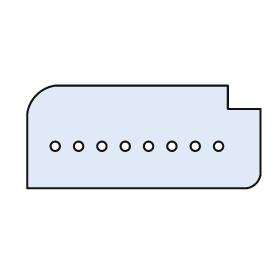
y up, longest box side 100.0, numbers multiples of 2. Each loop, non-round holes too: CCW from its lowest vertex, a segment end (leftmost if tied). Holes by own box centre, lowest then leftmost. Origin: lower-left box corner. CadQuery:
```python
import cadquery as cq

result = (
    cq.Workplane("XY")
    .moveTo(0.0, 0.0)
    .lineTo(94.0, 0.0)
    .threePointArc((98.0, 2.0), (100.0, 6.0))
    .lineTo(100.0, 34.0)
    .lineTo(86.0, 34.0)
    .lineTo(86.0, 44.0)
    .lineTo(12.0, 44.0)
    .threePointArc((4.0, 40.0), (0.0, 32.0))
    .close()
    .moveTo(12.0, 18.0)
    .circle(2.0)
    .moveTo(22.0, 18.0)
    .circle(2.0)
    .moveTo(32.0, 18.0)
    .circle(2.0)
    .moveTo(42.0, 18.0)
    .circle(2.0)
    .moveTo(52.0, 18.0)
    .circle(2.0)
    .moveTo(62.0, 18.0)
    .circle(2.0)
    .moveTo(72.0, 18.0)
    .circle(2.0)
    .moveTo(82.0, 18.0)
    .circle(2.0)
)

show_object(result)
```